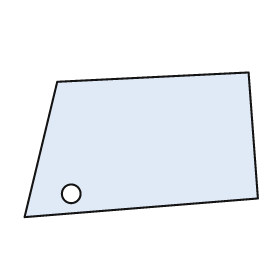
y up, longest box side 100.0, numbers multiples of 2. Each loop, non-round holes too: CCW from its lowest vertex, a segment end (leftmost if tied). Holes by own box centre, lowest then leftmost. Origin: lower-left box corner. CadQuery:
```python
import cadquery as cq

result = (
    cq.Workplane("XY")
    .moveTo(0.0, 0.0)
    .lineTo(100.0, 8.0)
    .lineTo(96.0, 62.0)
    .lineTo(14.0, 58.0)
    .close()
    .moveTo(20.0, 10.0)
    .circle(4.0)
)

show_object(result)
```